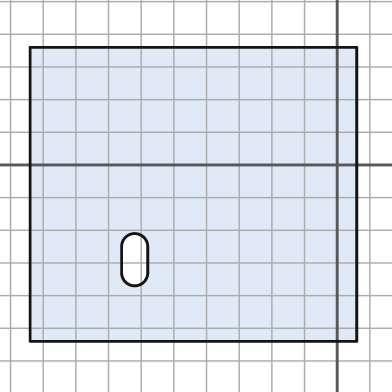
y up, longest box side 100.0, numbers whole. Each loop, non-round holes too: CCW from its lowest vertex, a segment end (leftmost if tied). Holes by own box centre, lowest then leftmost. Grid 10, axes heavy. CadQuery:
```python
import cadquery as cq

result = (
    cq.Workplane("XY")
    .moveTo(-94.0, -54.0)
    .lineTo(6.0, -54.0)
    .lineTo(6.0, 36.0)
    .lineTo(-94.0, 36.0)
    .close()
    .moveTo(-66.0, -33.0)
    .threePointArc((-62.0, -37.0), (-58.0, -33.0))
    .lineTo(-58.0, -25.0)
    .threePointArc((-62.0, -21.0), (-66.0, -25.0))
    .close()
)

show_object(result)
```